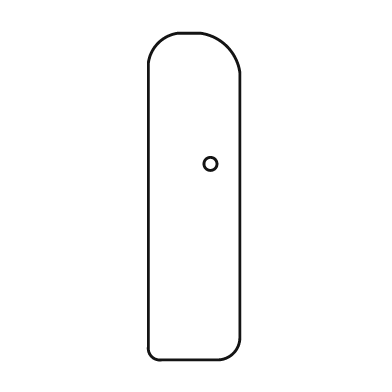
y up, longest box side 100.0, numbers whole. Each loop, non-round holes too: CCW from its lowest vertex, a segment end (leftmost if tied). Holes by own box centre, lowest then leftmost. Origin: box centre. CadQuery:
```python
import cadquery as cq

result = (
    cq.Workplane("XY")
    .moveTo(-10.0, -50.0)
    .lineTo(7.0, -50.0)
    .threePointArc((12.0, -48.0), (14.0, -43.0))
    .lineTo(14.0, 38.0)
    .threePointArc((10.0, 46.0), (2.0, 50.0))
    .lineTo(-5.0, 50.0)
    .threePointArc((-11.0, 47.0), (-14.0, 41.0))
    .lineTo(-14.0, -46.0)
    .threePointArc((-13.0, -49.0), (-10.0, -50.0))
    .close()
    .moveTo(5.0, 10.0)
    .circle(2.0)
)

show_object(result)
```